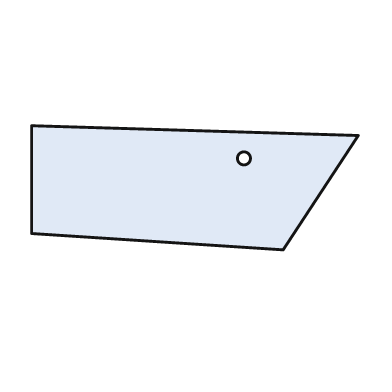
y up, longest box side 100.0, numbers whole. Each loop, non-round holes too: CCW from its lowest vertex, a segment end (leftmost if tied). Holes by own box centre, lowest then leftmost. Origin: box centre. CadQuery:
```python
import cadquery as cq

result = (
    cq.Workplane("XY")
    .moveTo(27.0, -19.0)
    .lineTo(50.0, 16.0)
    .lineTo(-50.0, 19.0)
    .lineTo(-50.0, -14.0)
    .close()
    .moveTo(15.0, 9.0)
    .circle(2.0)
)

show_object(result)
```